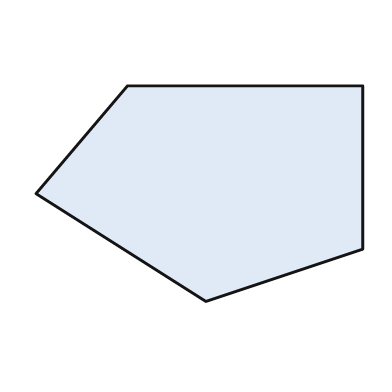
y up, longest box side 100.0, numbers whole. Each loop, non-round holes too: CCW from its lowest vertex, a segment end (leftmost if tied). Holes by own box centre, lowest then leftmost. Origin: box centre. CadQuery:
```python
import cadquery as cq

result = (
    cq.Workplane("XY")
    .moveTo(2.0, -33.0)
    .lineTo(50.0, -17.0)
    .lineTo(50.0, 33.0)
    .lineTo(-22.0, 33.0)
    .lineTo(-50.0, 0.0)
    .close()
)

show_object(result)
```